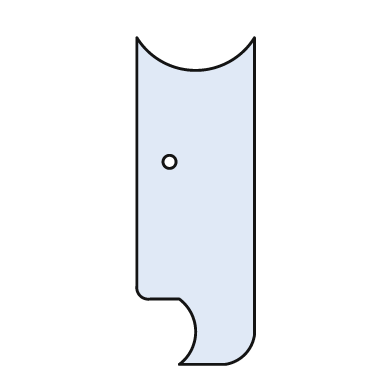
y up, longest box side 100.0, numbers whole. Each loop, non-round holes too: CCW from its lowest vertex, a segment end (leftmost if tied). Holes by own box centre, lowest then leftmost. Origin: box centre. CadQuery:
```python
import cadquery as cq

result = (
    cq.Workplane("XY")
    .moveTo(-5.0, -50.0)
    .lineTo(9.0, -50.0)
    .threePointArc((15.0, -47.0), (18.0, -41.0))
    .lineTo(18.0, 50.0)
    .threePointArc((0.0, 40.0), (-18.0, 50.0))
    .lineTo(-18.0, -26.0)
    .threePointArc((-17.0, -29.0), (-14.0, -30.0))
    .lineTo(-5.0, -30.0)
    .threePointArc((0.0, -40.0), (-5.0, -50.0))
    .close()
    .moveTo(-8.0, 12.0)
    .circle(2.0)
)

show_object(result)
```